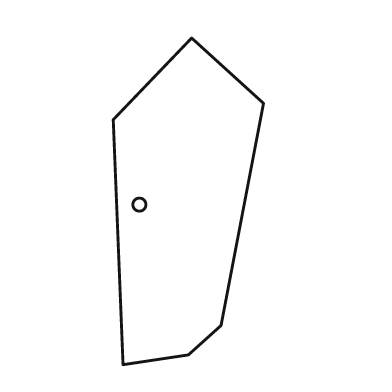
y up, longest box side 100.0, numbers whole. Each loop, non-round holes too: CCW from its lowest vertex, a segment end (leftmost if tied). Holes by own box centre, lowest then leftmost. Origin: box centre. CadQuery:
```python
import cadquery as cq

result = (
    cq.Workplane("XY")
    .moveTo(-20.0, -50.0)
    .lineTo(0.0, -47.0)
    .lineTo(10.0, -38.0)
    .lineTo(23.0, 30.0)
    .lineTo(1.0, 50.0)
    .lineTo(-23.0, 25.0)
    .close()
    .moveTo(-15.0, -1.0)
    .circle(2.0)
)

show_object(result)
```